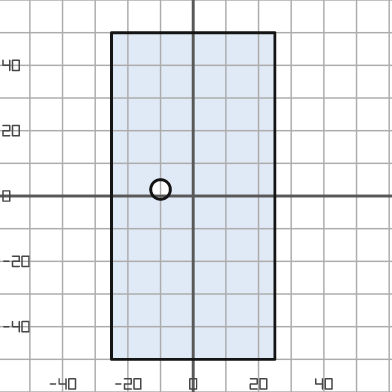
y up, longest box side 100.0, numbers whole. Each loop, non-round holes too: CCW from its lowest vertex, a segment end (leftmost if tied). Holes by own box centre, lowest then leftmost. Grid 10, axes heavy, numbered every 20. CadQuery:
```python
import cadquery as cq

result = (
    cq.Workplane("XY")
    .moveTo(-25.0, -50.0)
    .lineTo(25.0, -50.0)
    .lineTo(25.0, 50.0)
    .lineTo(-25.0, 50.0)
    .close()
    .moveTo(-10.0, 2.0)
    .circle(3.0)
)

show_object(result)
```